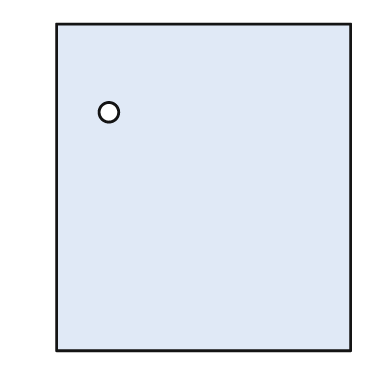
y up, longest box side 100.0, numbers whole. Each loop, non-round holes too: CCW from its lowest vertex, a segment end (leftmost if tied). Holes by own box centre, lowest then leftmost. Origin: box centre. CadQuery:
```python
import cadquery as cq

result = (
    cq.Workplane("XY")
    .moveTo(-45.0, -50.0)
    .lineTo(45.0, -50.0)
    .lineTo(45.0, 50.0)
    .lineTo(-45.0, 50.0)
    .close()
    .moveTo(-29.0, 23.0)
    .circle(3.0)
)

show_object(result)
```